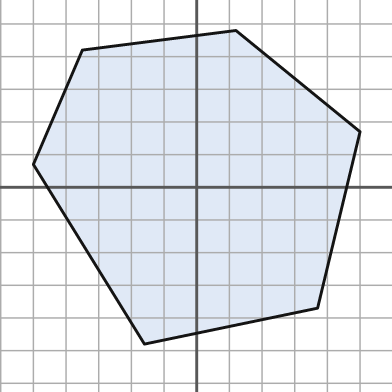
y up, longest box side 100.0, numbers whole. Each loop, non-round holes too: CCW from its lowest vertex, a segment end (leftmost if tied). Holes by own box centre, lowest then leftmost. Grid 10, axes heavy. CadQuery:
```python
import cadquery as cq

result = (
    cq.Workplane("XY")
    .moveTo(-16.0, -48.0)
    .lineTo(37.0, -37.0)
    .lineTo(50.0, 17.0)
    .lineTo(12.0, 48.0)
    .lineTo(-35.0, 42.0)
    .lineTo(-50.0, 7.0)
    .close()
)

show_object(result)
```